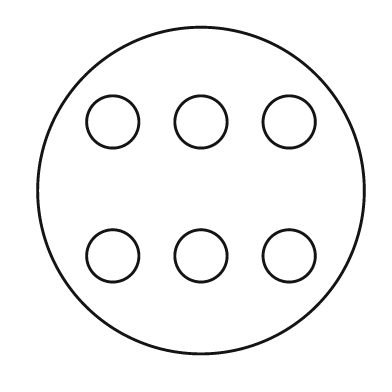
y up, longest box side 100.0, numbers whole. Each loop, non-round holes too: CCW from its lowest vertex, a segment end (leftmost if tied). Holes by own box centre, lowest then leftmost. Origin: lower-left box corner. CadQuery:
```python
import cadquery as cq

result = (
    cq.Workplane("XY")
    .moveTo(50.0, 50.0)
    .circle(50.0)
    .moveTo(23.0, 30.0)
    .circle(8.0)
    .moveTo(50.0, 30.0)
    .circle(8.0)
    .moveTo(77.0, 30.0)
    .circle(8.0)
    .moveTo(23.0, 71.0)
    .circle(8.0)
    .moveTo(50.0, 71.0)
    .circle(8.0)
    .moveTo(77.0, 71.0)
    .circle(8.0)
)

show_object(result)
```